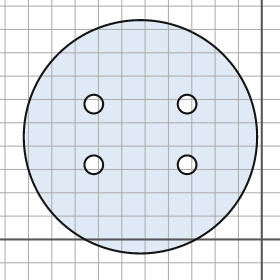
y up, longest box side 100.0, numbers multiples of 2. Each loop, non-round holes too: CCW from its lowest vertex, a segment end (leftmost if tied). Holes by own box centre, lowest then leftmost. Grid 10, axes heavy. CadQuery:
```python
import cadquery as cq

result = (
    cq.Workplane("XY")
    .moveTo(-52.0, 44.0)
    .circle(50.0)
    .moveTo(-72.0, 32.0)
    .circle(4.0)
    .moveTo(-32.0, 32.0)
    .circle(4.0)
    .moveTo(-72.0, 58.0)
    .circle(4.0)
    .moveTo(-32.0, 58.0)
    .circle(4.0)
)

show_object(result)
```